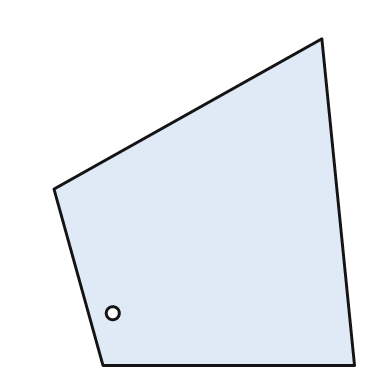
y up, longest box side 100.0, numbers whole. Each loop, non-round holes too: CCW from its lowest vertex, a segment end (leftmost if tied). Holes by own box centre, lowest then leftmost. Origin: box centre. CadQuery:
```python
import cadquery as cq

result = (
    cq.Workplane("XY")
    .moveTo(-31.0, -50.0)
    .lineTo(46.0, -50.0)
    .lineTo(36.0, 50.0)
    .lineTo(-46.0, 4.0)
    .close()
    .moveTo(-28.0, -34.0)
    .circle(2.0)
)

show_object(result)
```